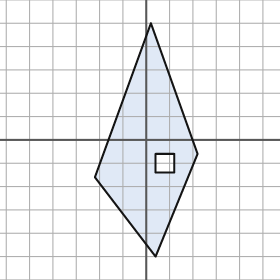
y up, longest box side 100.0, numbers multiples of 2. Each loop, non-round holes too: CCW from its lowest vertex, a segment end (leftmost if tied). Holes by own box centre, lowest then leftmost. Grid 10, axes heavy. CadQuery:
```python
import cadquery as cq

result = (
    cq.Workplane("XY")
    .moveTo(4.0, -50.0)
    .lineTo(22.0, -6.0)
    .lineTo(2.0, 50.0)
    .lineTo(-22.0, -16.0)
    .close()
    .moveTo(4.0, -14.0)
    .lineTo(12.0, -14.0)
    .lineTo(12.0, -6.0)
    .lineTo(4.0, -6.0)
    .close()
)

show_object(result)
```